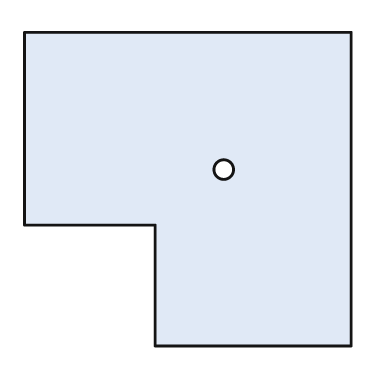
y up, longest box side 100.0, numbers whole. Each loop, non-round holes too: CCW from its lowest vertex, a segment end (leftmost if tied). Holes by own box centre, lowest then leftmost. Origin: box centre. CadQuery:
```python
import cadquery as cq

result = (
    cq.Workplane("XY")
    .moveTo(-10.0, -48.0)
    .lineTo(50.0, -48.0)
    .lineTo(50.0, 48.0)
    .lineTo(-50.0, 48.0)
    .lineTo(-50.0, -11.0)
    .lineTo(-10.0, -11.0)
    .close()
    .moveTo(11.0, 6.0)
    .circle(3.0)
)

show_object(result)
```